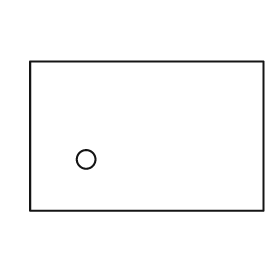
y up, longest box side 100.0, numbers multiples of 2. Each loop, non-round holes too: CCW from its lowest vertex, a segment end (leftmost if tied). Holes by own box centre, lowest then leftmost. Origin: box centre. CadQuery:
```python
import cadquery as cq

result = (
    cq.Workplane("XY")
    .moveTo(-50.0, -32.0)
    .lineTo(50.0, -32.0)
    .lineTo(50.0, 32.0)
    .lineTo(-50.0, 32.0)
    .close()
    .moveTo(-26.0, -10.0)
    .circle(4.0)
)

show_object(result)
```